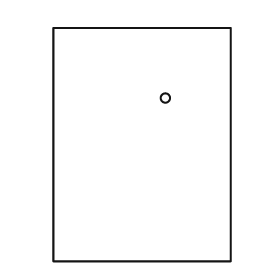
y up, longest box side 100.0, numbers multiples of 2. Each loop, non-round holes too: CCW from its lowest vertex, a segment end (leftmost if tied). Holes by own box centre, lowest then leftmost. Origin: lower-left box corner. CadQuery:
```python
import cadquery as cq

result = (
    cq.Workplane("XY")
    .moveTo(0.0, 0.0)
    .lineTo(76.0, 0.0)
    .lineTo(76.0, 100.0)
    .lineTo(0.0, 100.0)
    .close()
    .moveTo(48.0, 70.0)
    .circle(2.0)
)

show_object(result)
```